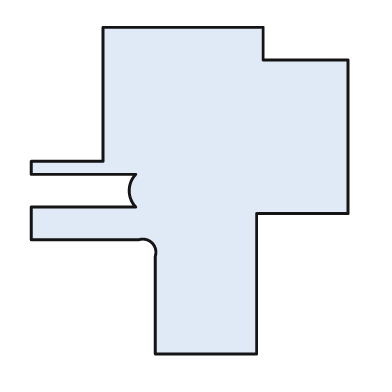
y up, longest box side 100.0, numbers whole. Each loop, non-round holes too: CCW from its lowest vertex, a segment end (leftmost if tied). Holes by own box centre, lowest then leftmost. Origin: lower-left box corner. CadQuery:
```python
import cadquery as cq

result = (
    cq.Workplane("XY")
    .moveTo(38.0, 0.0)
    .lineTo(69.0, 0.0)
    .lineTo(69.0, 43.0)
    .lineTo(97.0, 43.0)
    .lineTo(97.0, 90.0)
    .lineTo(71.0, 90.0)
    .lineTo(71.0, 100.0)
    .lineTo(22.0, 100.0)
    .lineTo(22.0, 59.0)
    .lineTo(0.0, 59.0)
    .lineTo(0.0, 55.0)
    .lineTo(32.0, 55.0)
    .threePointArc((30.0, 50.0), (32.0, 45.0))
    .lineTo(0.0, 45.0)
    .lineTo(0.0, 35.0)
    .lineTo(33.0, 35.0)
    .threePointArc((37.0, 34.0), (38.0, 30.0))
    .close()
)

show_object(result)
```